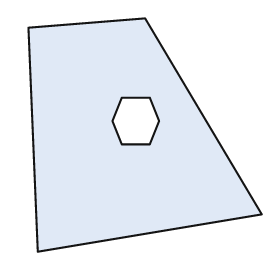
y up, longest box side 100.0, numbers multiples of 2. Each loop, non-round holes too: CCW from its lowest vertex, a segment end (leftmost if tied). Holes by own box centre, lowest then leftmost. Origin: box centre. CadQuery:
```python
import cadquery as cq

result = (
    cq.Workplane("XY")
    .moveTo(-46.0, -50.0)
    .lineTo(50.0, -34.0)
    .lineTo(0.0, 50.0)
    .lineTo(-50.0, 46.0)
    .close()
    .moveTo(-10.0, -4.0)
    .lineTo(2.0, -4.0)
    .lineTo(6.0, 6.0)
    .lineTo(2.0, 16.0)
    .lineTo(-10.0, 16.0)
    .lineTo(-14.0, 6.0)
    .close()
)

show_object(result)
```